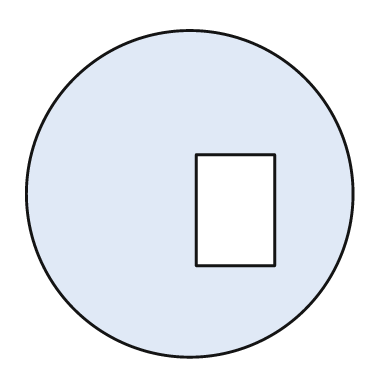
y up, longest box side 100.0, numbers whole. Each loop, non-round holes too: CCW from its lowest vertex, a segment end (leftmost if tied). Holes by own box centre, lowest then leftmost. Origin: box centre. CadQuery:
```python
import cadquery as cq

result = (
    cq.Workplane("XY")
    .moveTo(0.0, 0.0)
    .circle(50.0)
    .moveTo(2.0, -22.0)
    .lineTo(26.0, -22.0)
    .lineTo(26.0, 12.0)
    .lineTo(2.0, 12.0)
    .close()
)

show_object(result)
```